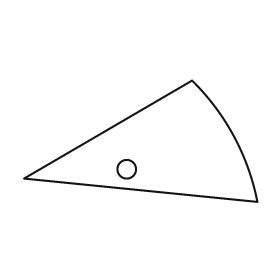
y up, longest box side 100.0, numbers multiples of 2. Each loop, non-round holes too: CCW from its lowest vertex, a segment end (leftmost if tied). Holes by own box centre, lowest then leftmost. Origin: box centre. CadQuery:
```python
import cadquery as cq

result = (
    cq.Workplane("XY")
    .moveTo(50.0, -26.0)
    .threePointArc((40.0, 2.0), (22.0, 26.0))
    .lineTo(-50.0, -16.0)
    .close()
    .moveTo(-6.0, -12.0)
    .circle(4.0)
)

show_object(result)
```